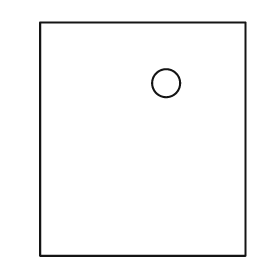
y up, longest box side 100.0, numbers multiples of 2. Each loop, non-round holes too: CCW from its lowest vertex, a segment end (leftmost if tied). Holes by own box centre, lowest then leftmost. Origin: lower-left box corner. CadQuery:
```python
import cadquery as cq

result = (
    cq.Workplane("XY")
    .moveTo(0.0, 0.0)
    .lineTo(88.0, 0.0)
    .lineTo(88.0, 100.0)
    .lineTo(0.0, 100.0)
    .close()
    .moveTo(54.0, 74.0)
    .circle(6.0)
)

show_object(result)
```